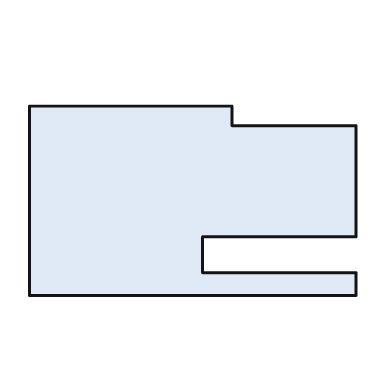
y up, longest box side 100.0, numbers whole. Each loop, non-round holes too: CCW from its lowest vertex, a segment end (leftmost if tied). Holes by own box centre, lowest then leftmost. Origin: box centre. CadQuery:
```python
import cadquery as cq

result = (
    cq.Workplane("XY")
    .moveTo(-50.0, -29.0)
    .lineTo(50.0, -29.0)
    .lineTo(50.0, -22.0)
    .lineTo(3.0, -22.0)
    .lineTo(3.0, -11.0)
    .lineTo(50.0, -11.0)
    .lineTo(50.0, 23.0)
    .lineTo(12.0, 23.0)
    .lineTo(12.0, 29.0)
    .lineTo(-50.0, 29.0)
    .close()
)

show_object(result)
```